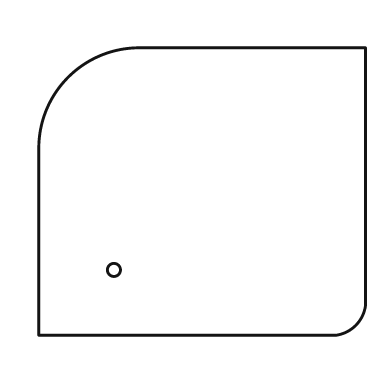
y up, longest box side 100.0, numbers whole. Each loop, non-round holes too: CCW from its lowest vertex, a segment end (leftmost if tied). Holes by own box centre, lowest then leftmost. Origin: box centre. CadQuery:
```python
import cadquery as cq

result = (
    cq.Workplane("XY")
    .moveTo(-50.0, -44.0)
    .lineTo(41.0, -44.0)
    .threePointArc((47.0, -41.0), (50.0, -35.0))
    .lineTo(50.0, 44.0)
    .lineTo(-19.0, 44.0)
    .threePointArc((-41.0, 35.0), (-50.0, 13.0))
    .close()
    .moveTo(-27.0, -24.0)
    .circle(2.0)
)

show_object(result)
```